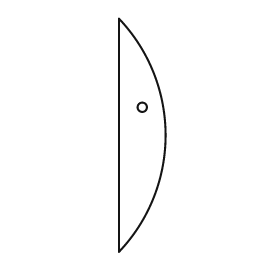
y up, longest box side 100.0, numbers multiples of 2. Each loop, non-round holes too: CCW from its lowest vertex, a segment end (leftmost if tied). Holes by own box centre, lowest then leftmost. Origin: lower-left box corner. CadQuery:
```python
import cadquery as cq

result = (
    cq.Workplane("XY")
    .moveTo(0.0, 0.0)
    .threePointArc((20.0, 50.0), (0.0, 100.0))
    .close()
    .moveTo(10.0, 62.0)
    .circle(2.0)
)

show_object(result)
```